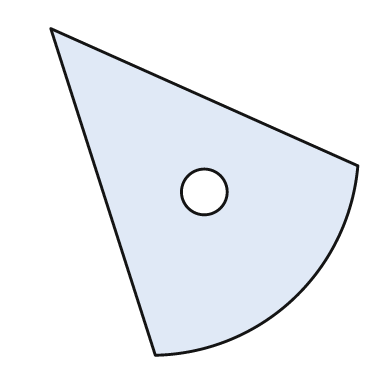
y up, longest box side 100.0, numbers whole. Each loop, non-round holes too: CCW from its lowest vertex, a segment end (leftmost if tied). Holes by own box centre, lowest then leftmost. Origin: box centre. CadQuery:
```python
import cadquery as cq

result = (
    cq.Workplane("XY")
    .moveTo(-15.0, -50.0)
    .threePointArc((27.0, -33.0), (47.0, 8.0))
    .lineTo(-47.0, 50.0)
    .close()
    .moveTo(0.0, 0.0)
    .circle(7.0)
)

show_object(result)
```